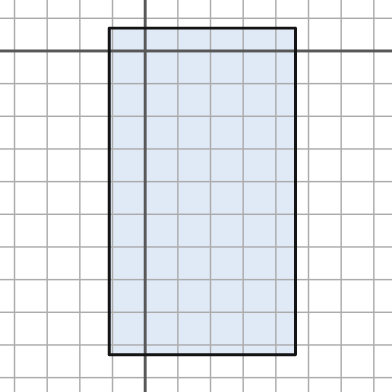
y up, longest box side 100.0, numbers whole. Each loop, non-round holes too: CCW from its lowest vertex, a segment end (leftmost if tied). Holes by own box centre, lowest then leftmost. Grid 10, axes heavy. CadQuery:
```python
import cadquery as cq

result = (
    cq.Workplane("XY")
    .moveTo(-11.0, -93.0)
    .lineTo(46.0, -93.0)
    .lineTo(46.0, 7.0)
    .lineTo(-11.0, 7.0)
    .close()
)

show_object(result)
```